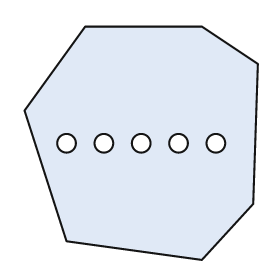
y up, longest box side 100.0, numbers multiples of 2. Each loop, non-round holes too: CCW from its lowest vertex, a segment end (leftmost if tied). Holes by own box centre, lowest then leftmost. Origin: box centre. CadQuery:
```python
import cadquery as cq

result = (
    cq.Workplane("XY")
    .moveTo(26.0, -50.0)
    .lineTo(48.0, -26.0)
    .lineTo(50.0, 34.0)
    .lineTo(26.0, 50.0)
    .lineTo(-24.0, 50.0)
    .lineTo(-50.0, 14.0)
    .lineTo(-32.0, -42.0)
    .close()
    .moveTo(-32.0, 0.0)
    .circle(4.0)
    .moveTo(-16.0, 0.0)
    .circle(4.0)
    .moveTo(0.0, 0.0)
    .circle(4.0)
    .moveTo(16.0, 0.0)
    .circle(4.0)
    .moveTo(32.0, 0.0)
    .circle(4.0)
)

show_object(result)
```